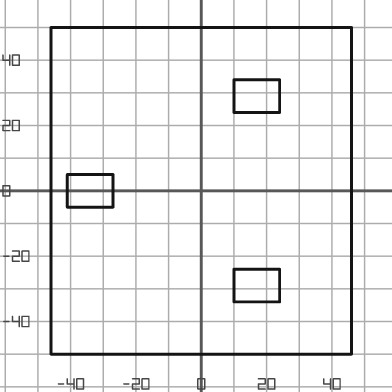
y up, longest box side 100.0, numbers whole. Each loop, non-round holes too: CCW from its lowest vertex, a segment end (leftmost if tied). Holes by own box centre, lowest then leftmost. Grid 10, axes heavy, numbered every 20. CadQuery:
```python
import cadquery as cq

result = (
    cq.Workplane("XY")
    .moveTo(-46.0, -50.0)
    .lineTo(46.0, -50.0)
    .lineTo(46.0, 50.0)
    .lineTo(-46.0, 50.0)
    .close()
    .moveTo(10.0, -34.0)
    .lineTo(24.0, -34.0)
    .lineTo(24.0, -24.0)
    .lineTo(10.0, -24.0)
    .close()
    .moveTo(-41.0, -5.0)
    .lineTo(-27.0, -5.0)
    .lineTo(-27.0, 5.0)
    .lineTo(-41.0, 5.0)
    .close()
    .moveTo(10.0, 24.0)
    .lineTo(24.0, 24.0)
    .lineTo(24.0, 34.0)
    .lineTo(10.0, 34.0)
    .close()
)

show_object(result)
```